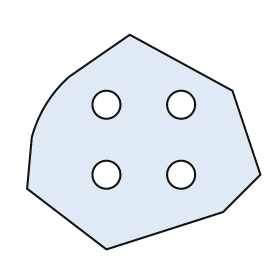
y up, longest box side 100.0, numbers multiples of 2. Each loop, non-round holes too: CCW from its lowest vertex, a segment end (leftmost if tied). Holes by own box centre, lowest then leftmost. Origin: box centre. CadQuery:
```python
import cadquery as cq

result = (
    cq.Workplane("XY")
    .moveTo(-16.0, -46.0)
    .lineTo(34.0, -30.0)
    .lineTo(50.0, -14.0)
    .lineTo(38.0, 22.0)
    .lineTo(-6.0, 46.0)
    .lineTo(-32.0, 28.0)
    .threePointArc((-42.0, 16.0), (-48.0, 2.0))
    .lineTo(-50.0, -20.0)
    .close()
    .moveTo(-16.0, -14.0)
    .circle(6.0)
    .moveTo(16.0, -14.0)
    .circle(6.0)
    .moveTo(-16.0, 16.0)
    .circle(6.0)
    .moveTo(16.0, 16.0)
    .circle(6.0)
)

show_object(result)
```